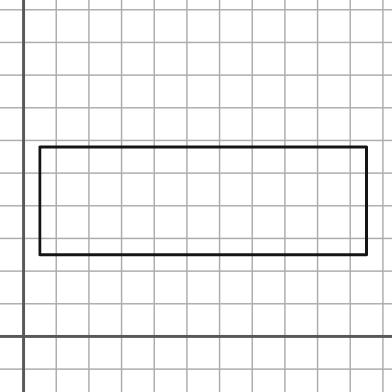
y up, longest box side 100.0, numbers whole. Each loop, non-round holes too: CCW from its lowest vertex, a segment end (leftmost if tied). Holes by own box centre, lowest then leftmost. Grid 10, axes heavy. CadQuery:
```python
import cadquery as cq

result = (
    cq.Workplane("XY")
    .moveTo(5.0, 25.0)
    .lineTo(105.0, 25.0)
    .lineTo(105.0, 58.0)
    .lineTo(5.0, 58.0)
    .close()
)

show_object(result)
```